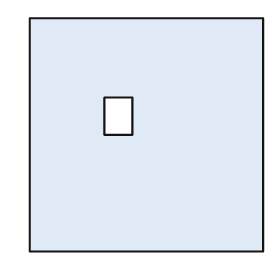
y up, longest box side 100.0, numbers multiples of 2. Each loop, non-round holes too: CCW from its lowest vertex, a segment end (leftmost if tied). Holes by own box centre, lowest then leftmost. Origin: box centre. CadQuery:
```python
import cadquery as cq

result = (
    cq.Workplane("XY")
    .moveTo(-50.0, -50.0)
    .lineTo(50.0, -50.0)
    .lineTo(50.0, 50.0)
    .lineTo(-50.0, 50.0)
    .close()
    .moveTo(-18.0, 0.0)
    .lineTo(-6.0, 0.0)
    .lineTo(-6.0, 16.0)
    .lineTo(-18.0, 16.0)
    .close()
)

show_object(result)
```